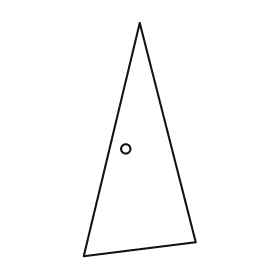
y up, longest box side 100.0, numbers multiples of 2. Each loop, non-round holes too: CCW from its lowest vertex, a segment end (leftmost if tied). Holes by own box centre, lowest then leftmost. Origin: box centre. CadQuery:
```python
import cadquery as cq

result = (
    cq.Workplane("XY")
    .moveTo(-24.0, -50.0)
    .lineTo(24.0, -44.0)
    .lineTo(0.0, 50.0)
    .close()
    .moveTo(-6.0, -4.0)
    .circle(2.0)
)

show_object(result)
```